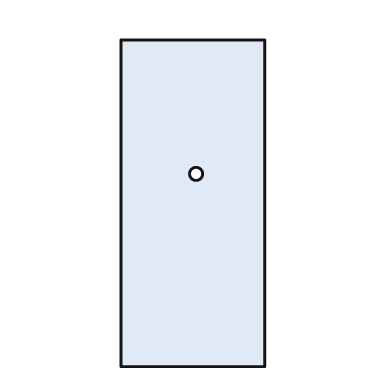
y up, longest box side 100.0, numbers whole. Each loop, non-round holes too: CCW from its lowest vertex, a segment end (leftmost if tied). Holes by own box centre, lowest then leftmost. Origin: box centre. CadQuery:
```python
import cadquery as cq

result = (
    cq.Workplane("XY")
    .moveTo(-22.0, -50.0)
    .lineTo(22.0, -50.0)
    .lineTo(22.0, 50.0)
    .lineTo(-22.0, 50.0)
    .close()
    .moveTo(1.0, 9.0)
    .circle(2.0)
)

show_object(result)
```